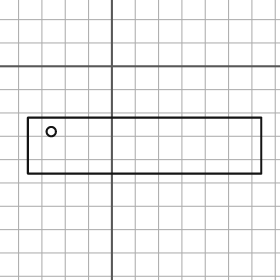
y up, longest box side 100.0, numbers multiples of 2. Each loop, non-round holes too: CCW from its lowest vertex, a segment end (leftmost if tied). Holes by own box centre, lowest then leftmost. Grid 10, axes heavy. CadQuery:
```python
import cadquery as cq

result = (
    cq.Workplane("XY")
    .moveTo(-36.0, -46.0)
    .lineTo(64.0, -46.0)
    .lineTo(64.0, -22.0)
    .lineTo(-36.0, -22.0)
    .close()
    .moveTo(-26.0, -28.0)
    .circle(2.0)
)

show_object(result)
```